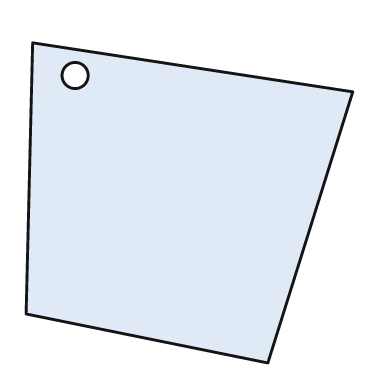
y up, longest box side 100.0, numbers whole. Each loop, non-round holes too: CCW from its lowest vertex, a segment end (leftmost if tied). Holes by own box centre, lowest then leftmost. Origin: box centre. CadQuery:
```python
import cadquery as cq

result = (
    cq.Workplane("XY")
    .moveTo(24.0, -49.0)
    .lineTo(50.0, 34.0)
    .lineTo(-48.0, 49.0)
    .lineTo(-50.0, -34.0)
    .close()
    .moveTo(-35.0, 39.0)
    .circle(4.0)
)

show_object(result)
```